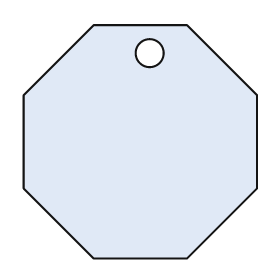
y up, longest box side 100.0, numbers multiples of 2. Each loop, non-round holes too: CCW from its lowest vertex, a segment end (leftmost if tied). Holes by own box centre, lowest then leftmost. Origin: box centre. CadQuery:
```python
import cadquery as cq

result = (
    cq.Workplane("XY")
    .moveTo(-20.0, -50.0)
    .lineTo(20.0, -50.0)
    .lineTo(50.0, -20.0)
    .lineTo(50.0, 20.0)
    .lineTo(20.0, 50.0)
    .lineTo(-20.0, 50.0)
    .lineTo(-50.0, 20.0)
    .lineTo(-50.0, -20.0)
    .close()
    .moveTo(4.0, 38.0)
    .circle(6.0)
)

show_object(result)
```